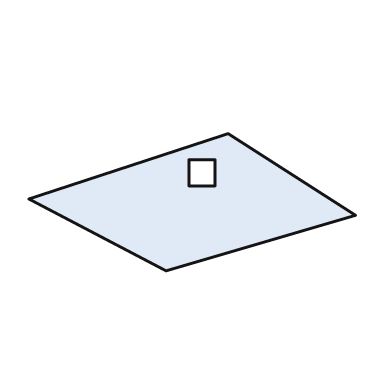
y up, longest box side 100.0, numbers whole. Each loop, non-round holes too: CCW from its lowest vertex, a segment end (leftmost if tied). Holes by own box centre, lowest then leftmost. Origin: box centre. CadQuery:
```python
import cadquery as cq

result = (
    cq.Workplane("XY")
    .moveTo(-8.0, -21.0)
    .lineTo(50.0, -4.0)
    .lineTo(11.0, 21.0)
    .lineTo(-50.0, 1.0)
    .close()
    .moveTo(-1.0, 5.0)
    .lineTo(7.0, 5.0)
    .lineTo(7.0, 13.0)
    .lineTo(-1.0, 13.0)
    .close()
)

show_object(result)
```